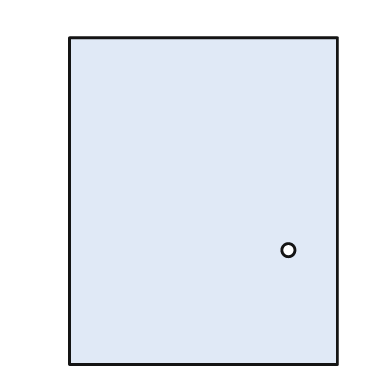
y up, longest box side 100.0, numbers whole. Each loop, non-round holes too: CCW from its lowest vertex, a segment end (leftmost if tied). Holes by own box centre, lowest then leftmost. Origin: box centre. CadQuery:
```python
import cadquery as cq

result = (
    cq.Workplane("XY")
    .moveTo(-41.0, -50.0)
    .lineTo(41.0, -50.0)
    .lineTo(41.0, 50.0)
    .lineTo(-41.0, 50.0)
    .close()
    .moveTo(26.0, -15.0)
    .circle(2.0)
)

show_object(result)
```